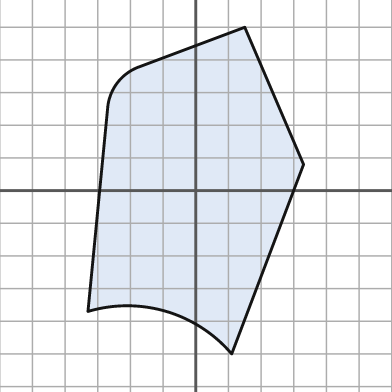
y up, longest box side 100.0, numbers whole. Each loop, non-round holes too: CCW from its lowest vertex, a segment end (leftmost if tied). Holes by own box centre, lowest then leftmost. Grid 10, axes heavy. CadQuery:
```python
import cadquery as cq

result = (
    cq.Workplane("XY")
    .moveTo(11.0, -50.0)
    .lineTo(33.0, 8.0)
    .lineTo(15.0, 50.0)
    .lineTo(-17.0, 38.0)
    .threePointArc((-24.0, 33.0), (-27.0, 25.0))
    .lineTo(-33.0, -37.0)
    .threePointArc((-9.0, -37.0), (11.0, -50.0))
    .close()
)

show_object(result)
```